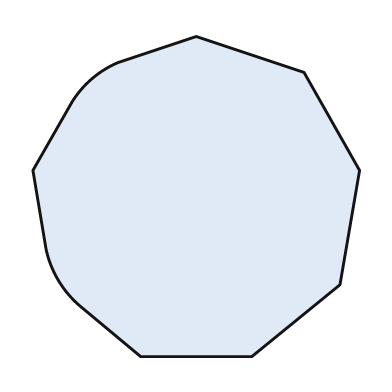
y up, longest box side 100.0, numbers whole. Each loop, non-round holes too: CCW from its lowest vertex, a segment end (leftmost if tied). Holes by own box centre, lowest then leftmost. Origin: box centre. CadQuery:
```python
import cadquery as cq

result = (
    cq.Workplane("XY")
    .moveTo(-17.0, -49.0)
    .lineTo(17.0, -49.0)
    .lineTo(44.0, -27.0)
    .lineTo(50.0, 8.0)
    .lineTo(33.0, 38.0)
    .lineTo(0.0, 49.0)
    .lineTo(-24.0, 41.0)
    .threePointArc((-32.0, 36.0), (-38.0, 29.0))
    .lineTo(-50.0, 8.0)
    .lineTo(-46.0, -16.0)
    .threePointArc((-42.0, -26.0), (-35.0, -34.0))
    .close()
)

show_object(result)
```